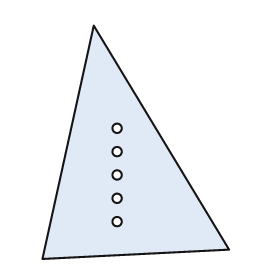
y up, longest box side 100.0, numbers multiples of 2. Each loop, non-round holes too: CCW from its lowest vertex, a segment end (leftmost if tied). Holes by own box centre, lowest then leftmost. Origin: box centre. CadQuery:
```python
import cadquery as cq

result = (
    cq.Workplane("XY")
    .moveTo(-40.0, -50.0)
    .lineTo(40.0, -46.0)
    .lineTo(-18.0, 50.0)
    .close()
    .moveTo(-8.0, -34.0)
    .circle(2.0)
    .moveTo(-8.0, -24.0)
    .circle(2.0)
    .moveTo(-8.0, -14.0)
    .circle(2.0)
    .moveTo(-8.0, -4.0)
    .circle(2.0)
    .moveTo(-8.0, 6.0)
    .circle(2.0)
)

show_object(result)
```